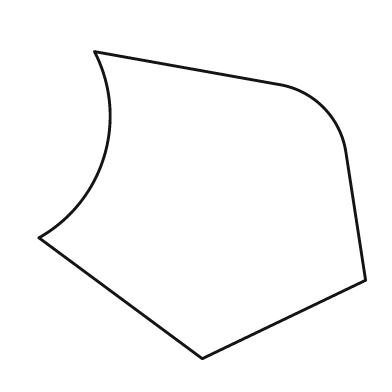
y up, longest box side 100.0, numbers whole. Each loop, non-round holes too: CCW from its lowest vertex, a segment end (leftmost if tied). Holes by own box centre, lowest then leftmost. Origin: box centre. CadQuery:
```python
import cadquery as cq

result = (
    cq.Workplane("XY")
    .moveTo(0.0, -47.0)
    .lineTo(50.0, -23.0)
    .lineTo(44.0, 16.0)
    .threePointArc((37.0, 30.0), (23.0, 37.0))
    .lineTo(-33.0, 47.0)
    .threePointArc((-30.0, 15.0), (-50.0, -10.0))
    .close()
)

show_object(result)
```